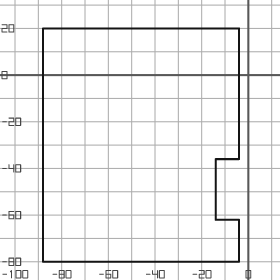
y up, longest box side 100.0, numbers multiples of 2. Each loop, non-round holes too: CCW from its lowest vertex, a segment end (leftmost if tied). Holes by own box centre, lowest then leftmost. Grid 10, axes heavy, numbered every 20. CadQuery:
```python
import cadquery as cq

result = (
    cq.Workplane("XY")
    .moveTo(-88.0, -80.0)
    .lineTo(-4.0, -80.0)
    .lineTo(-4.0, -62.0)
    .lineTo(-14.0, -62.0)
    .lineTo(-14.0, -36.0)
    .lineTo(-4.0, -36.0)
    .lineTo(-4.0, 20.0)
    .lineTo(-88.0, 20.0)
    .close()
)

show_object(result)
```